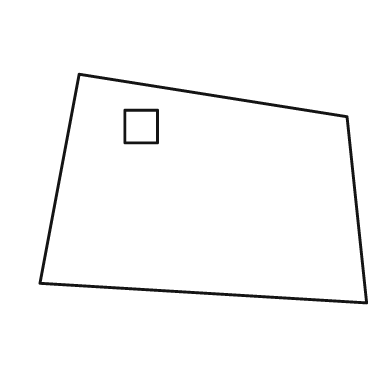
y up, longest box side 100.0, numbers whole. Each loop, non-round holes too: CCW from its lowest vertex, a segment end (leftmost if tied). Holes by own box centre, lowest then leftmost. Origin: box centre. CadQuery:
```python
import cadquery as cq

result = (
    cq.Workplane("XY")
    .moveTo(50.0, -35.0)
    .lineTo(44.0, 22.0)
    .lineTo(-38.0, 35.0)
    .lineTo(-50.0, -29.0)
    .close()
    .moveTo(-24.0, 14.0)
    .lineTo(-14.0, 14.0)
    .lineTo(-14.0, 24.0)
    .lineTo(-24.0, 24.0)
    .close()
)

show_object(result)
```